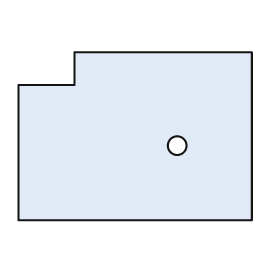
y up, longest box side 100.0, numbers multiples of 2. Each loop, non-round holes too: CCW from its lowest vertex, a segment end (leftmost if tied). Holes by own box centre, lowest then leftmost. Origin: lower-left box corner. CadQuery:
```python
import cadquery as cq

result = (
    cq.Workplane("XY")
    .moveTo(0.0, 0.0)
    .lineTo(100.0, 0.0)
    .lineTo(100.0, 72.0)
    .lineTo(24.0, 72.0)
    .lineTo(24.0, 58.0)
    .lineTo(0.0, 58.0)
    .close()
    .moveTo(68.0, 32.0)
    .circle(4.0)
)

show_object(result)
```